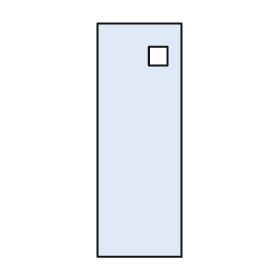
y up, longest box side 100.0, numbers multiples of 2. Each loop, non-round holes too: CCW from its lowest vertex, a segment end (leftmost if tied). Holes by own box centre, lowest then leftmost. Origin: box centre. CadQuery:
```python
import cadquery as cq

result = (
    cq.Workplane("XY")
    .moveTo(-18.0, -50.0)
    .lineTo(18.0, -50.0)
    .lineTo(18.0, 50.0)
    .lineTo(-18.0, 50.0)
    .close()
    .moveTo(4.0, 32.0)
    .lineTo(12.0, 32.0)
    .lineTo(12.0, 40.0)
    .lineTo(4.0, 40.0)
    .close()
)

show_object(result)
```